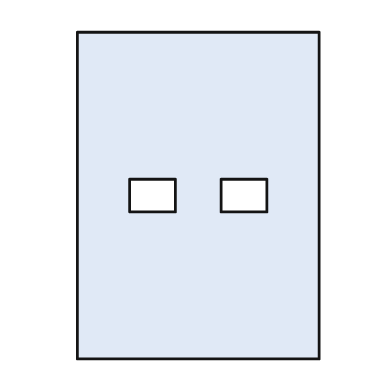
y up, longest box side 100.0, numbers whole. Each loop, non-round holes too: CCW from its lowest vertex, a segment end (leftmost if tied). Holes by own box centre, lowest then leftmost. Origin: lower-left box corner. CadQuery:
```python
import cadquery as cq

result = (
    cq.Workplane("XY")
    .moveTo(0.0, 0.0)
    .lineTo(74.0, 0.0)
    .lineTo(74.0, 100.0)
    .lineTo(0.0, 100.0)
    .close()
    .moveTo(16.0, 45.0)
    .lineTo(30.0, 45.0)
    .lineTo(30.0, 55.0)
    .lineTo(16.0, 55.0)
    .close()
    .moveTo(44.0, 45.0)
    .lineTo(58.0, 45.0)
    .lineTo(58.0, 55.0)
    .lineTo(44.0, 55.0)
    .close()
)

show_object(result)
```